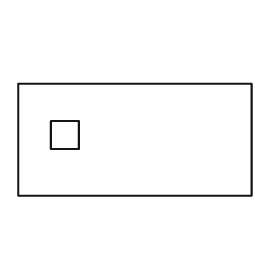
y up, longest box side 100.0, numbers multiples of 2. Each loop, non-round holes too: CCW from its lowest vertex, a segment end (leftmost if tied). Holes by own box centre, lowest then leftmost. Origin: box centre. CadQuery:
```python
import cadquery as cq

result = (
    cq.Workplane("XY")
    .moveTo(-50.0, -24.0)
    .lineTo(50.0, -24.0)
    .lineTo(50.0, 24.0)
    .lineTo(-50.0, 24.0)
    .close()
    .moveTo(-36.0, -4.0)
    .lineTo(-24.0, -4.0)
    .lineTo(-24.0, 8.0)
    .lineTo(-36.0, 8.0)
    .close()
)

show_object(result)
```